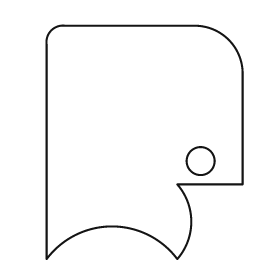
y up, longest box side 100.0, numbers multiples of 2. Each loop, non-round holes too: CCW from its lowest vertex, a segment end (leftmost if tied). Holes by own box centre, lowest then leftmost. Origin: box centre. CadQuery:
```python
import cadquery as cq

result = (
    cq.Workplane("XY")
    .moveTo(-42.0, -50.0)
    .threePointArc((-14.0, -36.0), (14.0, -50.0))
    .threePointArc((20.0, -34.0), (14.0, -18.0))
    .lineTo(42.0, -18.0)
    .lineTo(42.0, 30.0)
    .threePointArc((36.0, 44.0), (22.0, 50.0))
    .lineTo(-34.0, 50.0)
    .threePointArc((-40.0, 48.0), (-42.0, 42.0))
    .close()
    .moveTo(24.0, -8.0)
    .circle(6.0)
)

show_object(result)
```